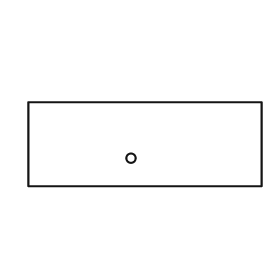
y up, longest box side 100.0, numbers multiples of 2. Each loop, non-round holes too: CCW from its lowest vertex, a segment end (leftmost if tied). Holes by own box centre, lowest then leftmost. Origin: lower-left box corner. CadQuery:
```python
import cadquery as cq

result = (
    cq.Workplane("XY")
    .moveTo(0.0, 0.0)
    .lineTo(100.0, 0.0)
    .lineTo(100.0, 36.0)
    .lineTo(0.0, 36.0)
    .close()
    .moveTo(44.0, 12.0)
    .circle(2.0)
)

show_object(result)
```